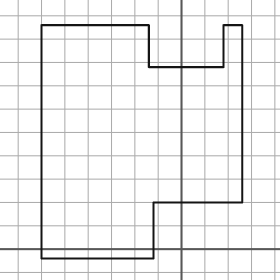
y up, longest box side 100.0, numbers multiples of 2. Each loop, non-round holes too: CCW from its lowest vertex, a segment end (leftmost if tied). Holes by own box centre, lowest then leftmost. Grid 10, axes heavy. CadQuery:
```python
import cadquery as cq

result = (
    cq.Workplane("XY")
    .moveTo(-60.0, -4.0)
    .lineTo(-12.0, -4.0)
    .lineTo(-12.0, 20.0)
    .lineTo(26.0, 20.0)
    .lineTo(26.0, 96.0)
    .lineTo(18.0, 96.0)
    .lineTo(18.0, 78.0)
    .lineTo(-14.0, 78.0)
    .lineTo(-14.0, 96.0)
    .lineTo(-60.0, 96.0)
    .close()
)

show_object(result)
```